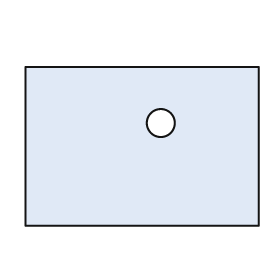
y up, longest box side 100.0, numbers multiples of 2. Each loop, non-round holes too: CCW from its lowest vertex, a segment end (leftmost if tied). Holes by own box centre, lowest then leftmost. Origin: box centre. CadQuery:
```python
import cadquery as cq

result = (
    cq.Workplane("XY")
    .moveTo(-50.0, -34.0)
    .lineTo(50.0, -34.0)
    .lineTo(50.0, 34.0)
    .lineTo(-50.0, 34.0)
    .close()
    .moveTo(8.0, 10.0)
    .circle(6.0)
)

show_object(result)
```